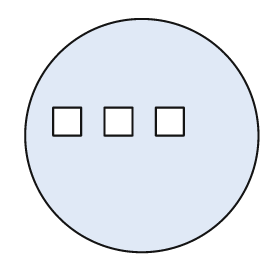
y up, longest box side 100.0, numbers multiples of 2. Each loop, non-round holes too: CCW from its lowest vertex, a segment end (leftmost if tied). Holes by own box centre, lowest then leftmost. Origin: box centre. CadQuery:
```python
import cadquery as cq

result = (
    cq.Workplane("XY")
    .moveTo(0.0, 0.0)
    .circle(50.0)
    .moveTo(-38.0, 0.0)
    .lineTo(-26.0, 0.0)
    .lineTo(-26.0, 12.0)
    .lineTo(-38.0, 12.0)
    .close()
    .moveTo(-16.0, 0.0)
    .lineTo(-4.0, 0.0)
    .lineTo(-4.0, 12.0)
    .lineTo(-16.0, 12.0)
    .close()
    .moveTo(6.0, 0.0)
    .lineTo(18.0, 0.0)
    .lineTo(18.0, 12.0)
    .lineTo(6.0, 12.0)
    .close()
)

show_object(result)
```